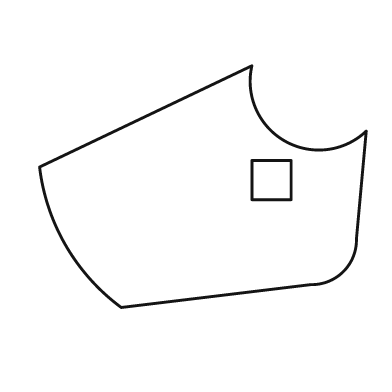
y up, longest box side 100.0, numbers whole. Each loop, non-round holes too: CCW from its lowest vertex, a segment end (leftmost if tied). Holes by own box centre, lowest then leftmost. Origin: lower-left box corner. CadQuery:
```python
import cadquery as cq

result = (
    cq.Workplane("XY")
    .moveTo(25.0, 0.0)
    .lineTo(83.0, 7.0)
    .threePointArc((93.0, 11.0), (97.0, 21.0))
    .lineTo(100.0, 54.0)
    .threePointArc((75.0, 51.0), (65.0, 74.0))
    .lineTo(0.0, 43.0)
    .threePointArc((8.0, 19.0), (25.0, 0.0))
    .close()
    .moveTo(65.0, 33.0)
    .lineTo(77.0, 33.0)
    .lineTo(77.0, 45.0)
    .lineTo(65.0, 45.0)
    .close()
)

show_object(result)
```